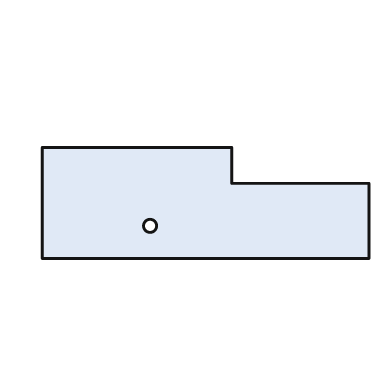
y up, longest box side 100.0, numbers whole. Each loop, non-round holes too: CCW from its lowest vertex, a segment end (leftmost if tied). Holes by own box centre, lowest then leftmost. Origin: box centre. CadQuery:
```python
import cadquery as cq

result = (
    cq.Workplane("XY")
    .moveTo(-50.0, -17.0)
    .lineTo(50.0, -17.0)
    .lineTo(50.0, 6.0)
    .lineTo(8.0, 6.0)
    .lineTo(8.0, 17.0)
    .lineTo(-50.0, 17.0)
    .close()
    .moveTo(-17.0, -7.0)
    .circle(2.0)
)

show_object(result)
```